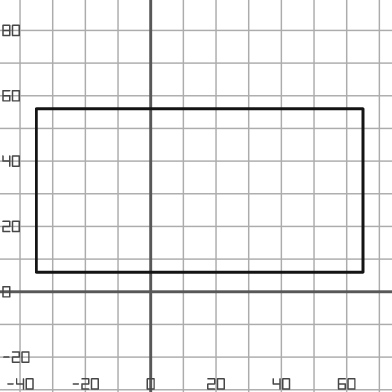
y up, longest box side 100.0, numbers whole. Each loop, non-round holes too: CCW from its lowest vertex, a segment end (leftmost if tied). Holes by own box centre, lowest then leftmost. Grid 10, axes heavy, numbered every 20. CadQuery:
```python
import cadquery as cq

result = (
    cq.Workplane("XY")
    .moveTo(-35.0, 6.0)
    .lineTo(65.0, 6.0)
    .lineTo(65.0, 56.0)
    .lineTo(-35.0, 56.0)
    .close()
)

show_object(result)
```